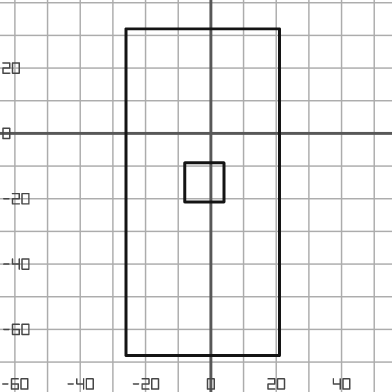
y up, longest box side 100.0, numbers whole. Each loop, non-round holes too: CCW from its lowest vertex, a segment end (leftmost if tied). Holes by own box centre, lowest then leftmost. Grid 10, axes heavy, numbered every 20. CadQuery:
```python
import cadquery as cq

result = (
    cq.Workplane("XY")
    .moveTo(-26.0, -68.0)
    .lineTo(21.0, -68.0)
    .lineTo(21.0, 32.0)
    .lineTo(-26.0, 32.0)
    .close()
    .moveTo(-8.0, -21.0)
    .lineTo(4.0, -21.0)
    .lineTo(4.0, -9.0)
    .lineTo(-8.0, -9.0)
    .close()
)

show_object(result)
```